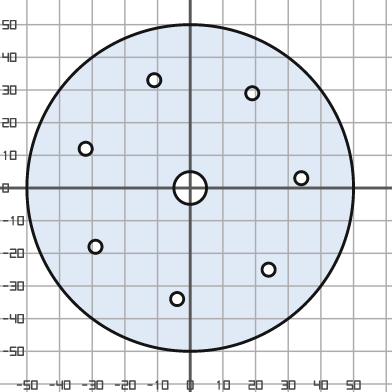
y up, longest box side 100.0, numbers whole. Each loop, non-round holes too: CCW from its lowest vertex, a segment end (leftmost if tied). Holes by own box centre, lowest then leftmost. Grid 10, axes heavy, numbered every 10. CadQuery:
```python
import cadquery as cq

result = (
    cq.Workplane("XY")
    .moveTo(0.0, 0.0)
    .circle(50.0)
    .moveTo(-4.0, -34.0)
    .circle(2.0)
    .moveTo(24.0, -25.0)
    .circle(2.0)
    .moveTo(-29.0, -18.0)
    .circle(2.0)
    .moveTo(0.0, 0.0)
    .circle(5.0)
    .moveTo(34.0, 3.0)
    .circle(2.0)
    .moveTo(-32.0, 12.0)
    .circle(2.0)
    .moveTo(19.0, 29.0)
    .circle(2.0)
    .moveTo(-11.0, 33.0)
    .circle(2.0)
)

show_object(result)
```